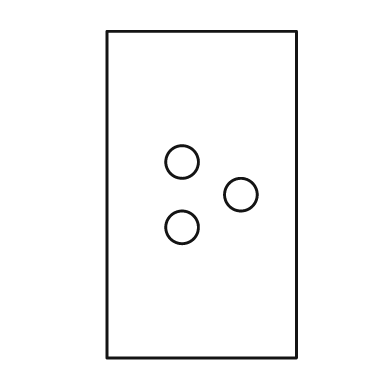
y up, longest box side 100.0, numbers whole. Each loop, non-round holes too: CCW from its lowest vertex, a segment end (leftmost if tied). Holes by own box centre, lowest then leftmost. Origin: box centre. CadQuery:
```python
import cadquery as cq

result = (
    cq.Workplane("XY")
    .moveTo(-29.0, -50.0)
    .lineTo(29.0, -50.0)
    .lineTo(29.0, 50.0)
    .lineTo(-29.0, 50.0)
    .close()
    .moveTo(-6.0, -10.0)
    .circle(5.0)
    .moveTo(12.0, 0.0)
    .circle(5.0)
    .moveTo(-6.0, 10.0)
    .circle(5.0)
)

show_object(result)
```